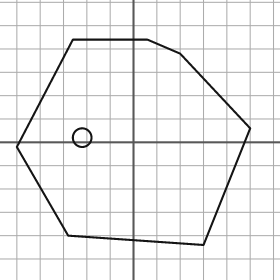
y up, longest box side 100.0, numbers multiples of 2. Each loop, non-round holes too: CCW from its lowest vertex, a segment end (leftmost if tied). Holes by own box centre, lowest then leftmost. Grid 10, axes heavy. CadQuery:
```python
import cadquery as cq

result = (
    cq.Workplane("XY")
    .moveTo(30.0, -44.0)
    .lineTo(50.0, 6.0)
    .lineTo(20.0, 38.0)
    .lineTo(6.0, 44.0)
    .lineTo(-26.0, 44.0)
    .lineTo(-50.0, -2.0)
    .lineTo(-28.0, -40.0)
    .close()
    .moveTo(-22.0, 2.0)
    .circle(4.0)
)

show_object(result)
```